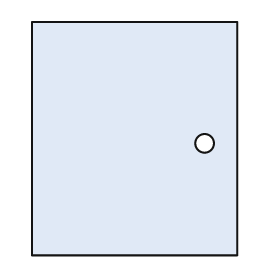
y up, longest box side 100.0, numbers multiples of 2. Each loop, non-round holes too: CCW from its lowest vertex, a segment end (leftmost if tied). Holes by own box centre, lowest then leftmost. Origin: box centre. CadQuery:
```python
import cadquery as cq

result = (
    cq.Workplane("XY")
    .moveTo(-44.0, -50.0)
    .lineTo(44.0, -50.0)
    .lineTo(44.0, 50.0)
    .lineTo(-44.0, 50.0)
    .close()
    .moveTo(30.0, -2.0)
    .circle(4.0)
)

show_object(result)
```